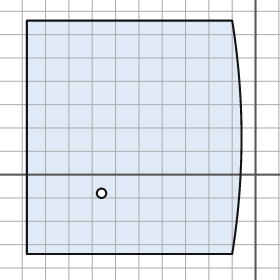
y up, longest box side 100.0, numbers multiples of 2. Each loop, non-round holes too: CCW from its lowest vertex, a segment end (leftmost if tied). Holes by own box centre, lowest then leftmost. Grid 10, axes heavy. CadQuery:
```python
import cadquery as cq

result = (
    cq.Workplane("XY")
    .moveTo(-98.0, -34.0)
    .lineTo(-10.0, -34.0)
    .threePointArc((-6.0, 16.0), (-10.0, 66.0))
    .lineTo(-98.0, 66.0)
    .close()
    .moveTo(-66.0, -8.0)
    .circle(2.0)
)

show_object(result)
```